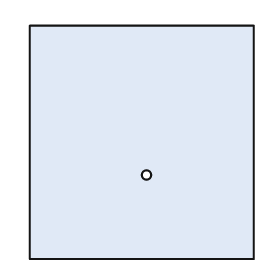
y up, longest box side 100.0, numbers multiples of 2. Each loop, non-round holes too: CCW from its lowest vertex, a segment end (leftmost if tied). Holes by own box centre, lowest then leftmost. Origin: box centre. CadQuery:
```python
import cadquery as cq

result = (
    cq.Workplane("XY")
    .moveTo(-48.0, -50.0)
    .lineTo(48.0, -50.0)
    .lineTo(48.0, 50.0)
    .lineTo(-48.0, 50.0)
    .close()
    .moveTo(2.0, -14.0)
    .circle(2.0)
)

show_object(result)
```